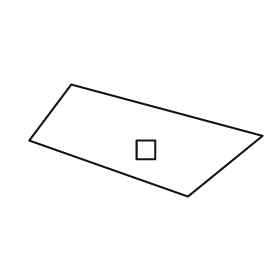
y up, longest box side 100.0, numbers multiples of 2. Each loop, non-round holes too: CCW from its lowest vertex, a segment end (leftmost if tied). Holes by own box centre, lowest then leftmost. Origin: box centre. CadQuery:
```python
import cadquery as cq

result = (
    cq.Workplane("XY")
    .moveTo(18.0, -24.0)
    .lineTo(50.0, 2.0)
    .lineTo(-32.0, 24.0)
    .lineTo(-50.0, 0.0)
    .close()
    .moveTo(-4.0, -8.0)
    .lineTo(4.0, -8.0)
    .lineTo(4.0, 0.0)
    .lineTo(-4.0, 0.0)
    .close()
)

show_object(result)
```